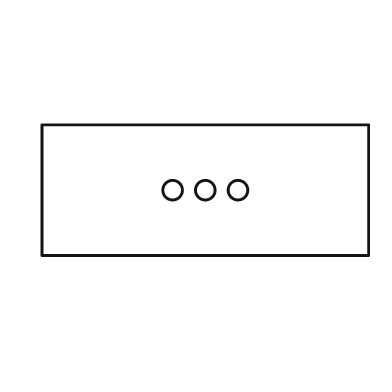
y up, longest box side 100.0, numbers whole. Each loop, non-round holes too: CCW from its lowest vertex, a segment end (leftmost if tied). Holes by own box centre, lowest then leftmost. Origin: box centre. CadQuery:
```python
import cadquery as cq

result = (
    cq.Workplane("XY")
    .moveTo(-50.0, -20.0)
    .lineTo(50.0, -20.0)
    .lineTo(50.0, 20.0)
    .lineTo(-50.0, 20.0)
    .close()
    .moveTo(-10.0, 0.0)
    .circle(3.0)
    .moveTo(0.0, 0.0)
    .circle(3.0)
    .moveTo(10.0, 0.0)
    .circle(3.0)
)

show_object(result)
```